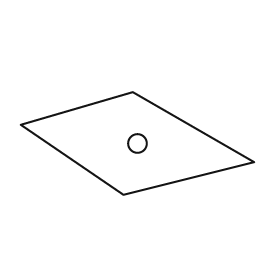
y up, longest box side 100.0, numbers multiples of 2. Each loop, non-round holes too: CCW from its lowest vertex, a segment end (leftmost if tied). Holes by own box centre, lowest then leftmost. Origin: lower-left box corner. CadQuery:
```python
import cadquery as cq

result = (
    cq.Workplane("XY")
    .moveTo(44.0, 0.0)
    .lineTo(100.0, 14.0)
    .lineTo(48.0, 44.0)
    .lineTo(0.0, 30.0)
    .close()
    .moveTo(50.0, 22.0)
    .circle(4.0)
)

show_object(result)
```